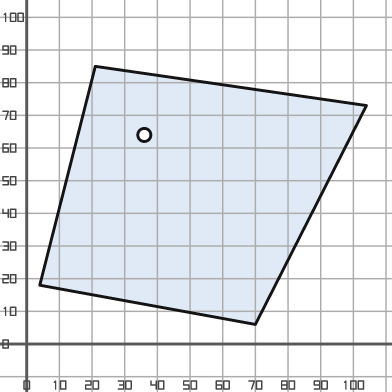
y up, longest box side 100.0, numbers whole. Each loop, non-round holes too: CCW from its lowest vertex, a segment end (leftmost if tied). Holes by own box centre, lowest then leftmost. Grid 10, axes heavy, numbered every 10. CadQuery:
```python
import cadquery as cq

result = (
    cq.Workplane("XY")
    .moveTo(70.0, 6.0)
    .lineTo(104.0, 73.0)
    .lineTo(21.0, 85.0)
    .lineTo(4.0, 18.0)
    .close()
    .moveTo(36.0, 64.0)
    .circle(2.0)
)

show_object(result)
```